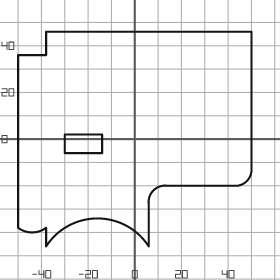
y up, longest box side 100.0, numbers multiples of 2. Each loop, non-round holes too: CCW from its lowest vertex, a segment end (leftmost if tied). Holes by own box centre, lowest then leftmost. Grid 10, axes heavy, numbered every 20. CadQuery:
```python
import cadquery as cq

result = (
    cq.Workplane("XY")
    .moveTo(-38.0, -46.0)
    .threePointArc((-16.0, -34.0), (6.0, -46.0))
    .lineTo(6.0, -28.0)
    .threePointArc((8.0, -22.0), (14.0, -20.0))
    .lineTo(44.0, -20.0)
    .threePointArc((48.0, -18.0), (50.0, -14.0))
    .lineTo(50.0, 46.0)
    .lineTo(-38.0, 46.0)
    .lineTo(-38.0, 36.0)
    .lineTo(-50.0, 36.0)
    .lineTo(-50.0, -38.0)
    .threePointArc((-44.0, -40.0), (-38.0, -38.0))
    .close()
    .moveTo(-30.0, -6.0)
    .lineTo(-14.0, -6.0)
    .lineTo(-14.0, 2.0)
    .lineTo(-30.0, 2.0)
    .close()
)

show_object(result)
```